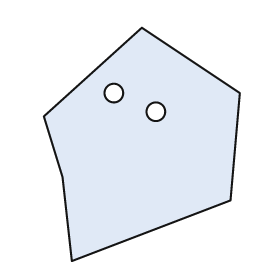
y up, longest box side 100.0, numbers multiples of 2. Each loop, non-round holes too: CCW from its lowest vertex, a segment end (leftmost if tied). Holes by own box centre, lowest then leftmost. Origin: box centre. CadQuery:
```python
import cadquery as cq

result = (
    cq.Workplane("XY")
    .moveTo(-30.0, -50.0)
    .lineTo(38.0, -24.0)
    .lineTo(42.0, 22.0)
    .lineTo(0.0, 50.0)
    .lineTo(-42.0, 12.0)
    .lineTo(-34.0, -14.0)
    .close()
    .moveTo(6.0, 14.0)
    .circle(4.0)
    .moveTo(-12.0, 22.0)
    .circle(4.0)
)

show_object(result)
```